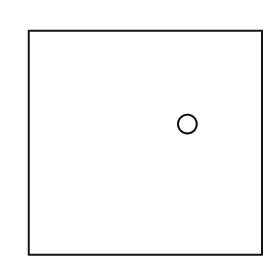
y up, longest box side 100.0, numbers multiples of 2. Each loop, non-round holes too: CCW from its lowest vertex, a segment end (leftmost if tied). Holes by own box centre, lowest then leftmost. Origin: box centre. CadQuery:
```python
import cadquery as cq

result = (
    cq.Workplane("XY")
    .moveTo(-50.0, -48.0)
    .lineTo(50.0, -48.0)
    .lineTo(50.0, 48.0)
    .lineTo(-50.0, 48.0)
    .close()
    .moveTo(18.0, 8.0)
    .circle(4.0)
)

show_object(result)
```